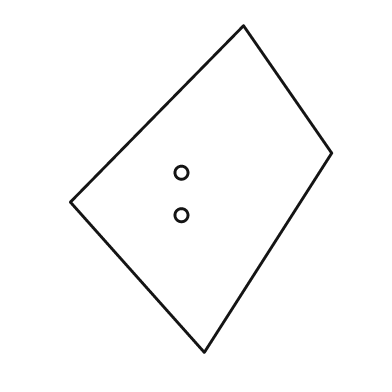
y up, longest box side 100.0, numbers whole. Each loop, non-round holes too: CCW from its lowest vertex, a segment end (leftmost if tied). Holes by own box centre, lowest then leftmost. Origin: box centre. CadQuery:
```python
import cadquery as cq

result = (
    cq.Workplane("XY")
    .moveTo(1.0, -50.0)
    .lineTo(40.0, 11.0)
    .lineTo(13.0, 50.0)
    .lineTo(-40.0, -4.0)
    .close()
    .moveTo(-6.0, -8.0)
    .circle(2.0)
    .moveTo(-6.0, 5.0)
    .circle(2.0)
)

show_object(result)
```